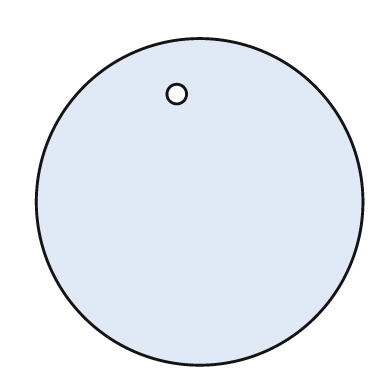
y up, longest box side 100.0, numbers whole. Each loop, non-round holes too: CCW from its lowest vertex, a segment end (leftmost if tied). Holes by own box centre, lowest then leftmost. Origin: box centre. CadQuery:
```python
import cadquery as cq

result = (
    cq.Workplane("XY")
    .moveTo(0.0, 0.0)
    .circle(50.0)
    .moveTo(-7.0, 33.0)
    .circle(3.0)
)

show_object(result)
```